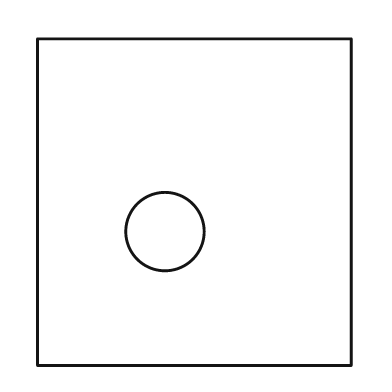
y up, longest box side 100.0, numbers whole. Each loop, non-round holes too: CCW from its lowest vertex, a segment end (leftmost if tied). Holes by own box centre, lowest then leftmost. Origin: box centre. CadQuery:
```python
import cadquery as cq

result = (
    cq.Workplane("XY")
    .moveTo(-48.0, -50.0)
    .lineTo(48.0, -50.0)
    .lineTo(48.0, 50.0)
    .lineTo(-48.0, 50.0)
    .close()
    .moveTo(-9.0, -9.0)
    .circle(12.0)
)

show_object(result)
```